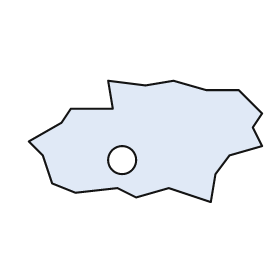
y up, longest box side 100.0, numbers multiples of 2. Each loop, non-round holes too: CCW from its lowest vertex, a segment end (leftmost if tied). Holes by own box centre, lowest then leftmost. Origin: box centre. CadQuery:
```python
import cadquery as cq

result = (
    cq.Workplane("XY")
    .moveTo(28.0, -26.0)
    .lineTo(30.0, -14.0)
    .lineTo(36.0, -6.0)
    .lineTo(50.0, -2.0)
    .lineTo(46.0, 6.0)
    .lineTo(50.0, 12.0)
    .lineTo(40.0, 22.0)
    .lineTo(26.0, 22.0)
    .lineTo(12.0, 26.0)
    .lineTo(0.0, 24.0)
    .lineTo(-16.0, 26.0)
    .lineTo(-14.0, 14.0)
    .lineTo(-32.0, 14.0)
    .lineTo(-36.0, 8.0)
    .lineTo(-50.0, 0.0)
    .lineTo(-44.0, -6.0)
    .lineTo(-40.0, -18.0)
    .lineTo(-30.0, -22.0)
    .lineTo(-12.0, -20.0)
    .lineTo(-4.0, -24.0)
    .lineTo(10.0, -20.0)
    .close()
    .moveTo(-10.0, -8.0)
    .circle(6.0)
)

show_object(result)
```